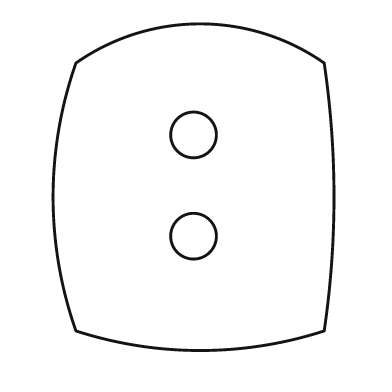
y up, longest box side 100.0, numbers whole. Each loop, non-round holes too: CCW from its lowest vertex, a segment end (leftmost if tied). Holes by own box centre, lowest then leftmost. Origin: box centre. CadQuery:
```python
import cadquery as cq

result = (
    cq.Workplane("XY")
    .moveTo(-36.0, -44.0)
    .threePointArc((2.0, -50.0), (40.0, -44.0))
    .threePointArc((43.0, -3.0), (40.0, 38.0))
    .threePointArc((2.0, 50.0), (-36.0, 38.0))
    .threePointArc((-43.0, -3.0), (-36.0, -44.0))
    .close()
    .moveTo(0.0, -15.0)
    .circle(7.0)
    .moveTo(0.0, 16.0)
    .circle(7.0)
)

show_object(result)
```